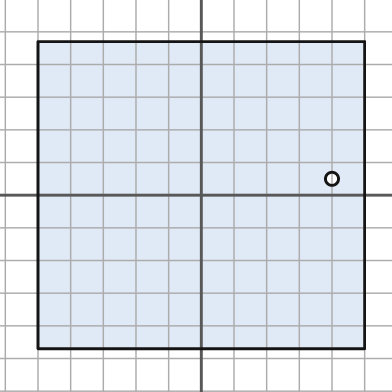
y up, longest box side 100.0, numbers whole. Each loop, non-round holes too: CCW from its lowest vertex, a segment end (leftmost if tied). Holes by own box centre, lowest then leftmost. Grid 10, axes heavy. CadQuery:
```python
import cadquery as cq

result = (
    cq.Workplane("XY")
    .moveTo(-50.0, -47.0)
    .lineTo(50.0, -47.0)
    .lineTo(50.0, 47.0)
    .lineTo(-50.0, 47.0)
    .close()
    .moveTo(40.0, 5.0)
    .circle(2.0)
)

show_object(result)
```